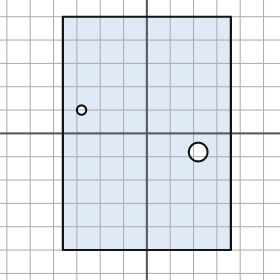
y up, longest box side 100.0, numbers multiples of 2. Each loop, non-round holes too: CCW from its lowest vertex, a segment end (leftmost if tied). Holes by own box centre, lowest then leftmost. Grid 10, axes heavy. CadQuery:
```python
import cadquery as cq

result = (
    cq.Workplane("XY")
    .moveTo(-36.0, -50.0)
    .lineTo(36.0, -50.0)
    .lineTo(36.0, 50.0)
    .lineTo(-36.0, 50.0)
    .close()
    .moveTo(22.0, -8.0)
    .circle(4.0)
    .moveTo(-28.0, 10.0)
    .circle(2.0)
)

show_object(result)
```